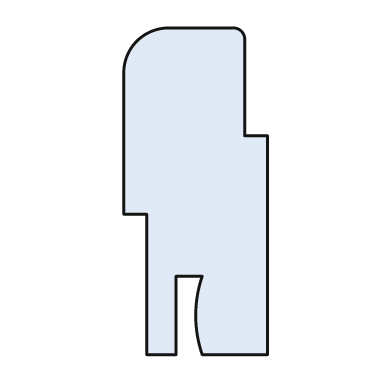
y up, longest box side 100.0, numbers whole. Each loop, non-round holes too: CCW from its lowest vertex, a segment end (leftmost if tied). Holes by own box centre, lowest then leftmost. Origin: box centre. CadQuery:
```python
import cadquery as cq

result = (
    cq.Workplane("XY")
    .moveTo(-15.0, -50.0)
    .lineTo(-6.0, -50.0)
    .lineTo(-6.0, -26.0)
    .lineTo(2.0, -26.0)
    .threePointArc((0.0, -38.0), (2.0, -50.0))
    .lineTo(22.0, -50.0)
    .lineTo(22.0, 17.0)
    .lineTo(15.0, 17.0)
    .lineTo(15.0, 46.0)
    .threePointArc((14.0, 49.0), (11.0, 50.0))
    .lineTo(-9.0, 50.0)
    .threePointArc((-18.0, 46.0), (-22.0, 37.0))
    .lineTo(-22.0, -7.0)
    .lineTo(-15.0, -7.0)
    .close()
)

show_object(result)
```